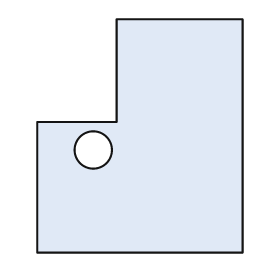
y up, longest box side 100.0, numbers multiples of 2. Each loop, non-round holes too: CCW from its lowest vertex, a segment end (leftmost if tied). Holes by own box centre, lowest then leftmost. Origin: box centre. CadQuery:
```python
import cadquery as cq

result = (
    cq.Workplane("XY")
    .moveTo(-44.0, -50.0)
    .lineTo(44.0, -50.0)
    .lineTo(44.0, 50.0)
    .lineTo(-10.0, 50.0)
    .lineTo(-10.0, 6.0)
    .lineTo(-44.0, 6.0)
    .close()
    .moveTo(-20.0, -6.0)
    .circle(8.0)
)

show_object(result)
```